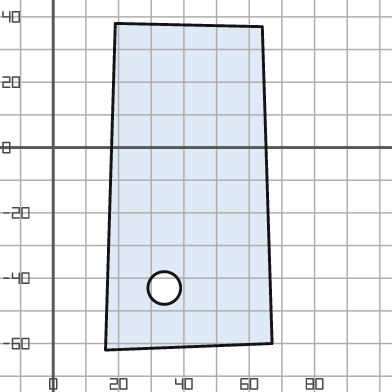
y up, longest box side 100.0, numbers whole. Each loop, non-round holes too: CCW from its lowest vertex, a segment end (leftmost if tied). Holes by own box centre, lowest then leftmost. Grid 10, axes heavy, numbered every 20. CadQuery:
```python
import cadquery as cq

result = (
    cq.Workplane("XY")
    .moveTo(16.0, -62.0)
    .lineTo(67.0, -60.0)
    .lineTo(64.0, 37.0)
    .lineTo(19.0, 38.0)
    .close()
    .moveTo(34.0, -43.0)
    .circle(5.0)
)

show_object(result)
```